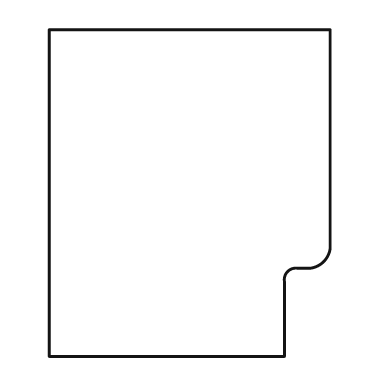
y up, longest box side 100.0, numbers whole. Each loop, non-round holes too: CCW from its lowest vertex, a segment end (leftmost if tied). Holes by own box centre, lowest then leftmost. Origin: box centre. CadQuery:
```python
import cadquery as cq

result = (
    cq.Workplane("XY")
    .moveTo(-43.0, -50.0)
    .lineTo(29.0, -50.0)
    .lineTo(29.0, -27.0)
    .threePointArc((30.0, -24.0), (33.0, -23.0))
    .lineTo(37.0, -23.0)
    .threePointArc((41.0, -21.0), (43.0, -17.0))
    .lineTo(43.0, 50.0)
    .lineTo(-43.0, 50.0)
    .close()
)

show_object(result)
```